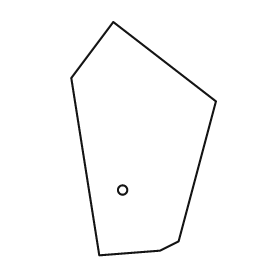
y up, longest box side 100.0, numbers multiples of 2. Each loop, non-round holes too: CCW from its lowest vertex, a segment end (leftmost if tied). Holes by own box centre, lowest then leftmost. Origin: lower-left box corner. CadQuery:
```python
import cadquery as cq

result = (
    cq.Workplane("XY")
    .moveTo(12.0, 0.0)
    .lineTo(38.0, 2.0)
    .lineTo(46.0, 6.0)
    .lineTo(62.0, 66.0)
    .lineTo(18.0, 100.0)
    .lineTo(0.0, 76.0)
    .close()
    .moveTo(22.0, 28.0)
    .circle(2.0)
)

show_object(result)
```